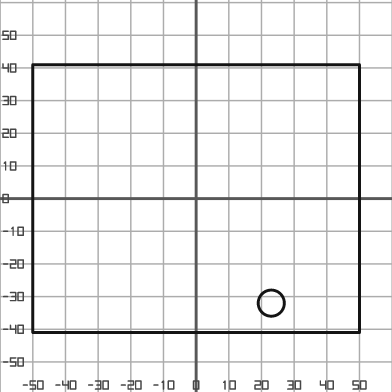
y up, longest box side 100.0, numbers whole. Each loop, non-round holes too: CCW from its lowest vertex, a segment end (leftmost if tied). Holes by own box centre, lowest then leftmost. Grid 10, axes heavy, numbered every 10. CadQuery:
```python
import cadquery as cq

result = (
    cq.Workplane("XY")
    .moveTo(-50.0, -41.0)
    .lineTo(50.0, -41.0)
    .lineTo(50.0, 41.0)
    .lineTo(-50.0, 41.0)
    .close()
    .moveTo(23.0, -32.0)
    .circle(4.0)
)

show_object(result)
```